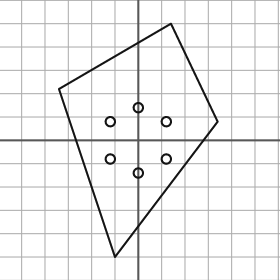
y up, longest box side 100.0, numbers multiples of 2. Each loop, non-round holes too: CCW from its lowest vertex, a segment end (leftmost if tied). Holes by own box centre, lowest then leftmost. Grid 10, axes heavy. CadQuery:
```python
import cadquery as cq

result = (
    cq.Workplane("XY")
    .moveTo(-10.0, -50.0)
    .lineTo(34.0, 8.0)
    .lineTo(14.0, 50.0)
    .lineTo(-34.0, 22.0)
    .close()
    .moveTo(0.0, -14.0)
    .circle(2.0)
    .moveTo(-12.0, -8.0)
    .circle(2.0)
    .moveTo(12.0, -8.0)
    .circle(2.0)
    .moveTo(-12.0, 8.0)
    .circle(2.0)
    .moveTo(12.0, 8.0)
    .circle(2.0)
    .moveTo(0.0, 14.0)
    .circle(2.0)
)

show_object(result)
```